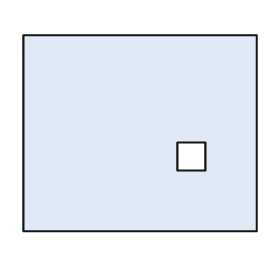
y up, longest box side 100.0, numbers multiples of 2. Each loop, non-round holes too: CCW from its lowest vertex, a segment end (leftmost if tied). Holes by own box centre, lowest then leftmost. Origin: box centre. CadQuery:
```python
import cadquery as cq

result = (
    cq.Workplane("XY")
    .moveTo(-50.0, -42.0)
    .lineTo(50.0, -42.0)
    .lineTo(50.0, 42.0)
    .lineTo(-50.0, 42.0)
    .close()
    .moveTo(16.0, -16.0)
    .lineTo(28.0, -16.0)
    .lineTo(28.0, -4.0)
    .lineTo(16.0, -4.0)
    .close()
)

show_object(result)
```